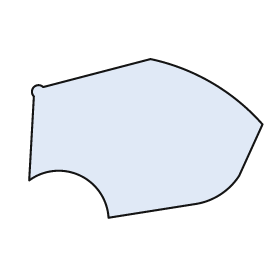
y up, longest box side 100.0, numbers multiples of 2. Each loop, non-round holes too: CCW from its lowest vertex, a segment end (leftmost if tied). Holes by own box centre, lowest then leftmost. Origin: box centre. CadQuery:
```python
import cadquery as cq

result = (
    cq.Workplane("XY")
    .moveTo(-16.0, -34.0)
    .lineTo(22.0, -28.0)
    .threePointArc((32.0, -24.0), (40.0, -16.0))
    .lineTo(50.0, 6.0)
    .threePointArc((28.0, 24.0), (2.0, 34.0))
    .lineTo(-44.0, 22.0)
    .threePointArc((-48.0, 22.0), (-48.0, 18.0))
    .lineTo(-50.0, -18.0)
    .threePointArc((-28.0, -16.0), (-16.0, -34.0))
    .close()
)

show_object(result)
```